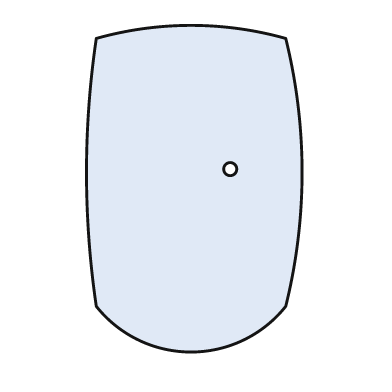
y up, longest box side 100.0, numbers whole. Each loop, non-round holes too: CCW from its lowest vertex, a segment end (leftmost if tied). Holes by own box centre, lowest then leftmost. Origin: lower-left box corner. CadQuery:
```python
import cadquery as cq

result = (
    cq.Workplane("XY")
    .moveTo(3.0, 14.0)
    .threePointArc((32.0, 0.0), (61.0, 14.0))
    .threePointArc((66.0, 55.0), (61.0, 96.0))
    .threePointArc((32.0, 100.0), (3.0, 96.0))
    .threePointArc((0.0, 55.0), (3.0, 14.0))
    .close()
    .moveTo(44.0, 56.0)
    .circle(2.0)
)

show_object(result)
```